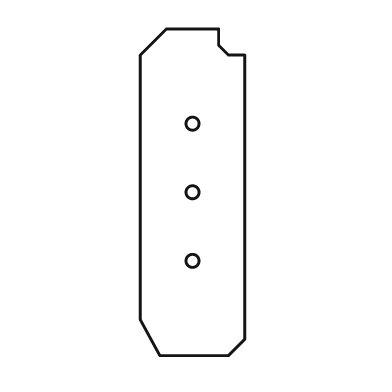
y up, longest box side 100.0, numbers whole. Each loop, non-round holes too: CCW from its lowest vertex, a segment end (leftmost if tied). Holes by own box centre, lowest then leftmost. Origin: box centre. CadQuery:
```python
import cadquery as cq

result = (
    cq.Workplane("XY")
    .moveTo(-10.0, -50.0)
    .lineTo(11.0, -50.0)
    .lineTo(16.0, -45.0)
    .lineTo(16.0, 42.0)
    .lineTo(11.0, 42.0)
    .lineTo(8.0, 45.0)
    .lineTo(8.0, 50.0)
    .lineTo(-8.0, 50.0)
    .lineTo(-16.0, 42.0)
    .lineTo(-16.0, -39.0)
    .close()
    .moveTo(0.0, -21.0)
    .circle(2.0)
    .moveTo(0.0, 0.0)
    .circle(2.0)
    .moveTo(0.0, 21.0)
    .circle(2.0)
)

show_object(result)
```